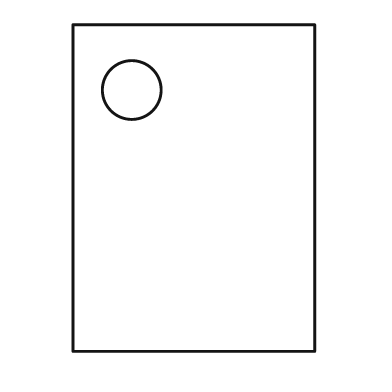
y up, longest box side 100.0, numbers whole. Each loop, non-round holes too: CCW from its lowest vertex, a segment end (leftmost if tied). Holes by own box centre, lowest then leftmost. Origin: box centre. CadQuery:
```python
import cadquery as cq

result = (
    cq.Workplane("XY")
    .moveTo(-37.0, -50.0)
    .lineTo(37.0, -50.0)
    .lineTo(37.0, 50.0)
    .lineTo(-37.0, 50.0)
    .close()
    .moveTo(-19.0, 30.0)
    .circle(9.0)
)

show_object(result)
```